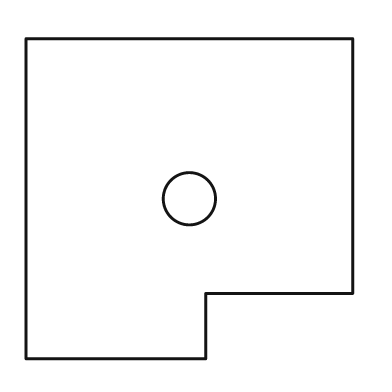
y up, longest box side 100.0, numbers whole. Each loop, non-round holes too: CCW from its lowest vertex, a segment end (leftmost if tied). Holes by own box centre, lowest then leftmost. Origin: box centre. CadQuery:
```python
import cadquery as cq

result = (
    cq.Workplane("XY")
    .moveTo(-50.0, -49.0)
    .lineTo(5.0, -49.0)
    .lineTo(5.0, -29.0)
    .lineTo(50.0, -29.0)
    .lineTo(50.0, 49.0)
    .lineTo(-50.0, 49.0)
    .close()
    .moveTo(0.0, 0.0)
    .circle(8.0)
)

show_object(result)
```